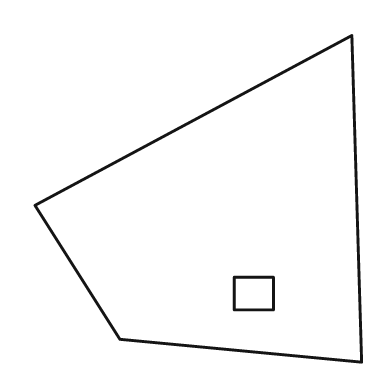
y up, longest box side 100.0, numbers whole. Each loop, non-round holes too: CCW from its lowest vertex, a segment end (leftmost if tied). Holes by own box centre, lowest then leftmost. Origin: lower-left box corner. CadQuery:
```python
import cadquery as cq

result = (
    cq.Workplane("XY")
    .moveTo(100.0, 0.0)
    .lineTo(97.0, 100.0)
    .lineTo(0.0, 48.0)
    .lineTo(26.0, 7.0)
    .close()
    .moveTo(61.0, 16.0)
    .lineTo(73.0, 16.0)
    .lineTo(73.0, 26.0)
    .lineTo(61.0, 26.0)
    .close()
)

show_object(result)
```